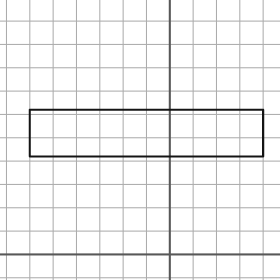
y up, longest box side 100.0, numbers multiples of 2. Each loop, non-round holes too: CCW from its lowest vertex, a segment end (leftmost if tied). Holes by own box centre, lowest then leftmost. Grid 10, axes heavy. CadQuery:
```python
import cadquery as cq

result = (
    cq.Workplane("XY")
    .moveTo(-60.0, 42.0)
    .lineTo(40.0, 42.0)
    .lineTo(40.0, 62.0)
    .lineTo(-60.0, 62.0)
    .close()
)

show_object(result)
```